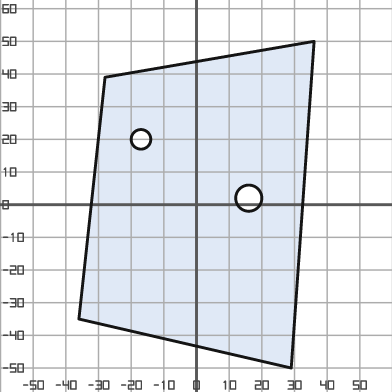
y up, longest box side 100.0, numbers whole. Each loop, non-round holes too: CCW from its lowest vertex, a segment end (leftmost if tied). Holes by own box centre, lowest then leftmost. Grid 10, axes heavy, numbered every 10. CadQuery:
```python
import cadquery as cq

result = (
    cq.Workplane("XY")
    .moveTo(29.0, -50.0)
    .lineTo(36.0, 50.0)
    .lineTo(-28.0, 39.0)
    .lineTo(-36.0, -35.0)
    .close()
    .moveTo(16.0, 2.0)
    .circle(4.0)
    .moveTo(-17.0, 20.0)
    .circle(3.0)
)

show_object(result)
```